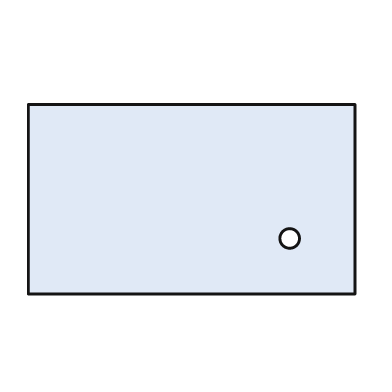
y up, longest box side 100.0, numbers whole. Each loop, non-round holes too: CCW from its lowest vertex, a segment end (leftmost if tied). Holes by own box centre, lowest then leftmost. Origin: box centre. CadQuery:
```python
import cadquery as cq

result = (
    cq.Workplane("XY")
    .moveTo(-50.0, -29.0)
    .lineTo(50.0, -29.0)
    .lineTo(50.0, 29.0)
    .lineTo(-50.0, 29.0)
    .close()
    .moveTo(30.0, -12.0)
    .circle(3.0)
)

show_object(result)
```